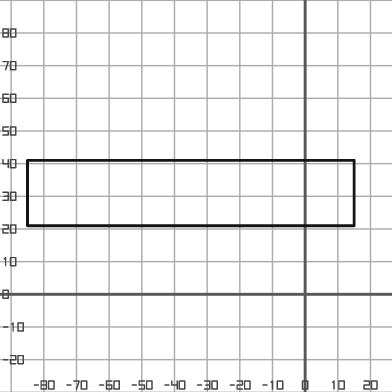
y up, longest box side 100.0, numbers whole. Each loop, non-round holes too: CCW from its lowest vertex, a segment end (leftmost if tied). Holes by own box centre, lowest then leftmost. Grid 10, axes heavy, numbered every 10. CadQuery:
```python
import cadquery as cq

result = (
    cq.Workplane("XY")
    .moveTo(-85.0, 21.0)
    .lineTo(15.0, 21.0)
    .lineTo(15.0, 41.0)
    .lineTo(-85.0, 41.0)
    .close()
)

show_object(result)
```